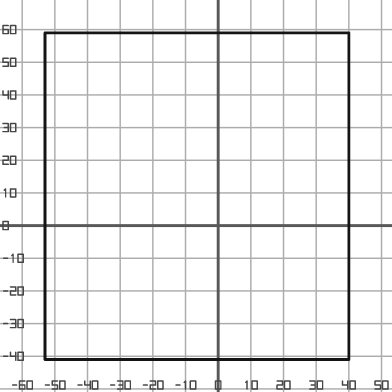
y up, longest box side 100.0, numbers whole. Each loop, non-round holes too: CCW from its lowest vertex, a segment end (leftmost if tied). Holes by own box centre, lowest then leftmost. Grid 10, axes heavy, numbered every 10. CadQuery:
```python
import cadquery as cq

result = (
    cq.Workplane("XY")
    .moveTo(-53.0, -41.0)
    .lineTo(40.0, -41.0)
    .lineTo(40.0, 59.0)
    .lineTo(-53.0, 59.0)
    .close()
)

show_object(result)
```